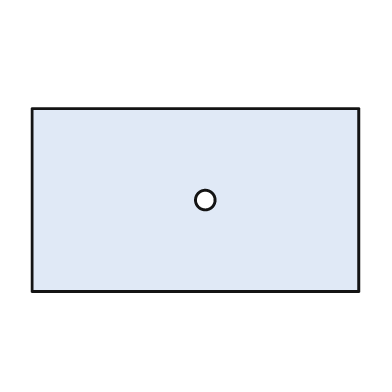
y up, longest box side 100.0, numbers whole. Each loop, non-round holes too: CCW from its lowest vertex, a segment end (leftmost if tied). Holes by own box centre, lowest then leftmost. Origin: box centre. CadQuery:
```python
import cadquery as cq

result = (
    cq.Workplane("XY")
    .moveTo(-50.0, -28.0)
    .lineTo(50.0, -28.0)
    .lineTo(50.0, 28.0)
    .lineTo(-50.0, 28.0)
    .close()
    .moveTo(3.0, 0.0)
    .circle(3.0)
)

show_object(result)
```